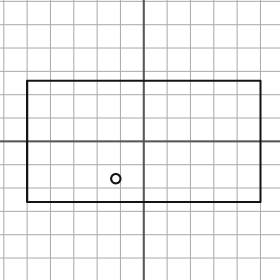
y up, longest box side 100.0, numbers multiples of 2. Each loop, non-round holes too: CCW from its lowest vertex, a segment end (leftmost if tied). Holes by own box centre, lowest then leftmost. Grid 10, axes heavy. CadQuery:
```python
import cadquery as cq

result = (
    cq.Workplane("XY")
    .moveTo(-50.0, -26.0)
    .lineTo(50.0, -26.0)
    .lineTo(50.0, 26.0)
    .lineTo(-50.0, 26.0)
    .close()
    .moveTo(-12.0, -16.0)
    .circle(2.0)
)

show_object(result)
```